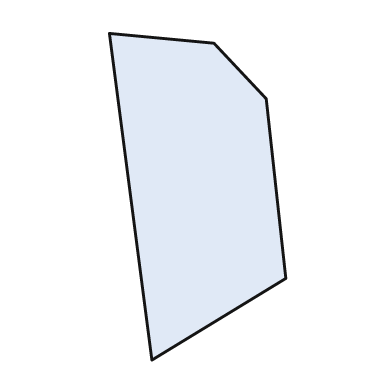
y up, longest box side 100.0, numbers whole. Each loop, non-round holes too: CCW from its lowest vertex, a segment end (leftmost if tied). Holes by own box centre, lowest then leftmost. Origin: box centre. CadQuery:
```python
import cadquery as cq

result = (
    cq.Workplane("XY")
    .moveTo(-14.0, -50.0)
    .lineTo(27.0, -25.0)
    .lineTo(21.0, 30.0)
    .lineTo(5.0, 47.0)
    .lineTo(-27.0, 50.0)
    .close()
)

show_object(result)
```